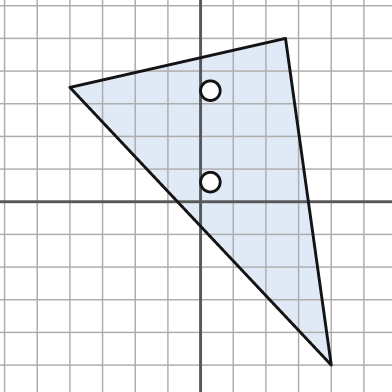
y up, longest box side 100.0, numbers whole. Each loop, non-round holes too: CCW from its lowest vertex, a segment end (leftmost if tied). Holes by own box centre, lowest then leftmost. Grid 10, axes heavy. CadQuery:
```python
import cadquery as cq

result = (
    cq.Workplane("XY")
    .moveTo(40.0, -50.0)
    .lineTo(26.0, 50.0)
    .lineTo(-40.0, 35.0)
    .close()
    .moveTo(3.0, 6.0)
    .circle(3.0)
    .moveTo(3.0, 34.0)
    .circle(3.0)
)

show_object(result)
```